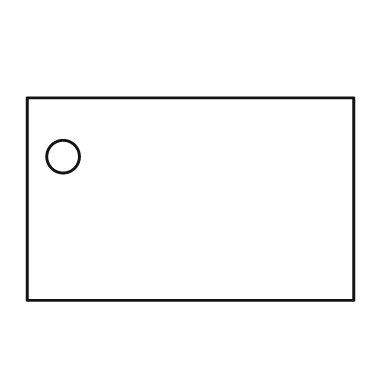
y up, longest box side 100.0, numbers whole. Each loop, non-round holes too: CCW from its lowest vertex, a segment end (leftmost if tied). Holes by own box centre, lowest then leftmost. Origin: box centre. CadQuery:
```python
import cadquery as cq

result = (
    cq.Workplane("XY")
    .moveTo(-50.0, -31.0)
    .lineTo(50.0, -31.0)
    .lineTo(50.0, 31.0)
    .lineTo(-50.0, 31.0)
    .close()
    .moveTo(-39.0, 13.0)
    .circle(5.0)
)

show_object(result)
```